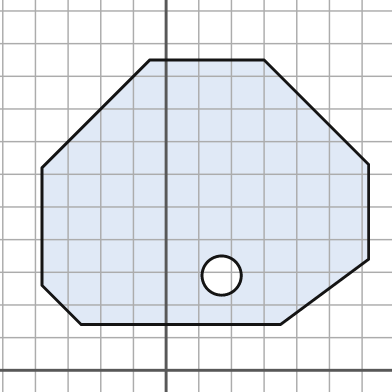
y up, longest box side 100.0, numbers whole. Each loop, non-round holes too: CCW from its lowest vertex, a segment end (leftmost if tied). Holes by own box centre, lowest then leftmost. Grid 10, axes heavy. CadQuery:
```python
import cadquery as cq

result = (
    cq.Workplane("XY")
    .moveTo(-26.0, 14.0)
    .lineTo(35.0, 14.0)
    .lineTo(62.0, 34.0)
    .lineTo(62.0, 63.0)
    .lineTo(30.0, 95.0)
    .lineTo(-5.0, 95.0)
    .lineTo(-38.0, 62.0)
    .lineTo(-38.0, 26.0)
    .close()
    .moveTo(17.0, 29.0)
    .circle(6.0)
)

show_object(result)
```